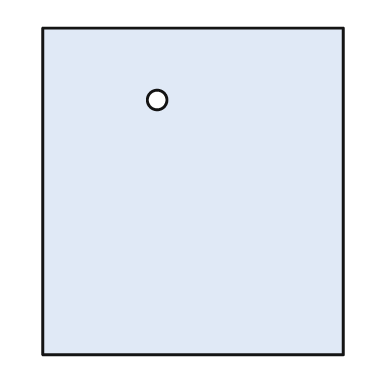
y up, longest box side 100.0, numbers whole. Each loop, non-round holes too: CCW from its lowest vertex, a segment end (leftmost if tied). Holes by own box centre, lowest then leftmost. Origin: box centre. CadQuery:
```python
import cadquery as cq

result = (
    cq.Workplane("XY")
    .moveTo(-46.0, -50.0)
    .lineTo(46.0, -50.0)
    .lineTo(46.0, 50.0)
    .lineTo(-46.0, 50.0)
    .close()
    .moveTo(-11.0, 28.0)
    .circle(3.0)
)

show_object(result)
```